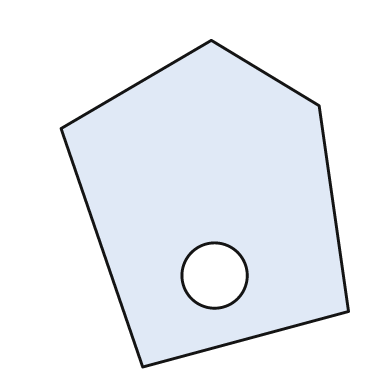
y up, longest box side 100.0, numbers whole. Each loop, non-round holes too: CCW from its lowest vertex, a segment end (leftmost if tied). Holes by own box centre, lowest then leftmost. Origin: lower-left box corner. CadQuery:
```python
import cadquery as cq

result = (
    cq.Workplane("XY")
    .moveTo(25.0, 0.0)
    .lineTo(88.0, 17.0)
    .lineTo(79.0, 80.0)
    .lineTo(46.0, 100.0)
    .lineTo(0.0, 73.0)
    .close()
    .moveTo(47.0, 28.0)
    .circle(10.0)
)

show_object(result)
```